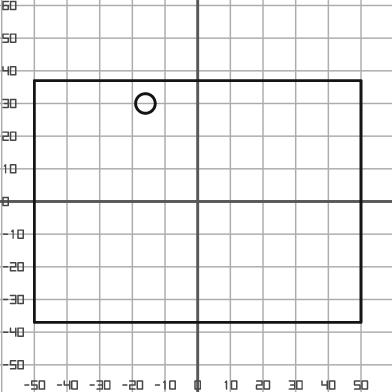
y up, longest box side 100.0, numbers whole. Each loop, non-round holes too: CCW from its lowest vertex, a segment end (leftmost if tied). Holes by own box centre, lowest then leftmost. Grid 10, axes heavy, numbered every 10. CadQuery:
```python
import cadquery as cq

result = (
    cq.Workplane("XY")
    .moveTo(-50.0, -37.0)
    .lineTo(50.0, -37.0)
    .lineTo(50.0, 37.0)
    .lineTo(-50.0, 37.0)
    .close()
    .moveTo(-16.0, 30.0)
    .circle(3.0)
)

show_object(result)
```